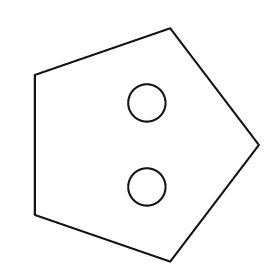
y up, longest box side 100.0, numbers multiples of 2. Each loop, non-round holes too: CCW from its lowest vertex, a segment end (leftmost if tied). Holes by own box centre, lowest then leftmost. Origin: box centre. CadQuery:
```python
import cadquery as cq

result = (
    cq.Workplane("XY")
    .moveTo(10.0, -50.0)
    .lineTo(48.0, 0.0)
    .lineTo(10.0, 50.0)
    .lineTo(-48.0, 30.0)
    .lineTo(-48.0, -30.0)
    .close()
    .moveTo(0.0, -18.0)
    .circle(8.0)
    .moveTo(0.0, 18.0)
    .circle(8.0)
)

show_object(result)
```